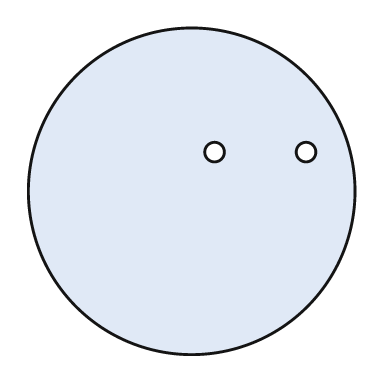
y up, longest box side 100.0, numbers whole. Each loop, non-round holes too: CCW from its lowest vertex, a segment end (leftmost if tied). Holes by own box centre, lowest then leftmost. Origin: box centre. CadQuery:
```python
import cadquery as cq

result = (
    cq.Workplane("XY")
    .moveTo(0.0, 0.0)
    .circle(50.0)
    .moveTo(7.0, 12.0)
    .circle(3.0)
    .moveTo(35.0, 12.0)
    .circle(3.0)
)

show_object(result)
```